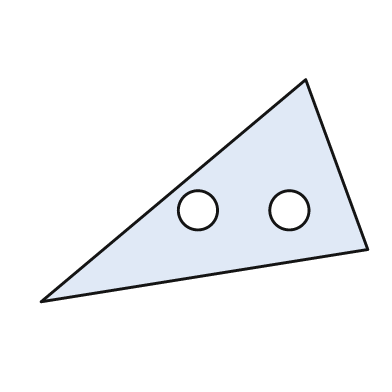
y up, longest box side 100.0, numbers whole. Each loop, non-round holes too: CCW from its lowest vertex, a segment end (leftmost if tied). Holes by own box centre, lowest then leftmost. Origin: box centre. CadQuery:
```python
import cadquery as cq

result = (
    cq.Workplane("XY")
    .moveTo(-50.0, -34.0)
    .lineTo(50.0, -18.0)
    .lineTo(31.0, 34.0)
    .close()
    .moveTo(-2.0, -6.0)
    .circle(6.0)
    .moveTo(26.0, -6.0)
    .circle(6.0)
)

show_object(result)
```